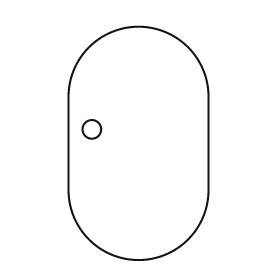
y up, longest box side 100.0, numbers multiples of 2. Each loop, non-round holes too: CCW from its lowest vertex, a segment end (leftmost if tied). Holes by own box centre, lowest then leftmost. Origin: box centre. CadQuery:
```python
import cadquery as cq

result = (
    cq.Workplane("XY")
    .moveTo(-30.0, -20.0)
    .threePointArc((0.0, -50.0), (30.0, -20.0))
    .lineTo(30.0, 20.0)
    .threePointArc((0.0, 50.0), (-30.0, 20.0))
    .close()
    .moveTo(-20.0, 6.0)
    .circle(4.0)
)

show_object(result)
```